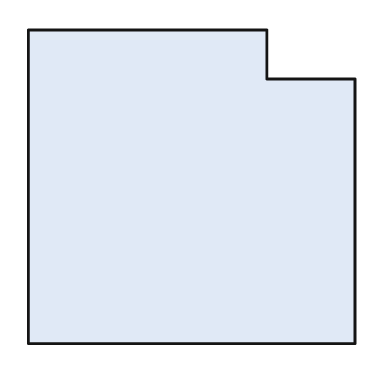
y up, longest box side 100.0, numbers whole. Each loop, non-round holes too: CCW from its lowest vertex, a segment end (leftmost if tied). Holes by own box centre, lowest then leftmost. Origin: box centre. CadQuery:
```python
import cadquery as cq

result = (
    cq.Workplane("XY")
    .moveTo(-50.0, -48.0)
    .lineTo(50.0, -48.0)
    .lineTo(50.0, 33.0)
    .lineTo(23.0, 33.0)
    .lineTo(23.0, 48.0)
    .lineTo(-50.0, 48.0)
    .close()
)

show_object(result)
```